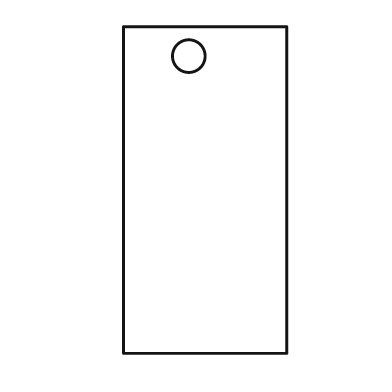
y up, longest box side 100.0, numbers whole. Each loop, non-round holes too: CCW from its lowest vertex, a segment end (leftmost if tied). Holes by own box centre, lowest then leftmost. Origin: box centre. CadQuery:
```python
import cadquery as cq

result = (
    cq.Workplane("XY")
    .moveTo(-25.0, -50.0)
    .lineTo(25.0, -50.0)
    .lineTo(25.0, 50.0)
    .lineTo(-25.0, 50.0)
    .close()
    .moveTo(-5.0, 41.0)
    .circle(5.0)
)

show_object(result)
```